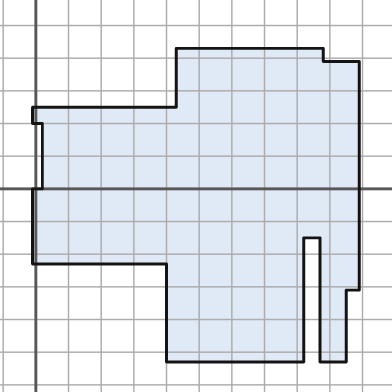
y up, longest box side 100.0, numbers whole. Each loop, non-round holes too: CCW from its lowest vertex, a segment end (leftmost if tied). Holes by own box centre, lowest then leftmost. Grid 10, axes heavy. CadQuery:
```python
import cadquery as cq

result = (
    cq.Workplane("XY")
    .moveTo(40.0, -53.0)
    .lineTo(82.0, -53.0)
    .lineTo(82.0, -15.0)
    .lineTo(87.0, -15.0)
    .lineTo(87.0, -53.0)
    .lineTo(95.0, -53.0)
    .lineTo(95.0, -31.0)
    .lineTo(99.0, -31.0)
    .lineTo(99.0, 39.0)
    .lineTo(88.0, 39.0)
    .lineTo(88.0, 43.0)
    .lineTo(43.0, 43.0)
    .lineTo(43.0, 25.0)
    .lineTo(-1.0, 25.0)
    .lineTo(-1.0, 20.0)
    .lineTo(2.0, 20.0)
    .lineTo(2.0, 0.0)
    .lineTo(-1.0, 0.0)
    .lineTo(-1.0, -23.0)
    .lineTo(40.0, -23.0)
    .close()
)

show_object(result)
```